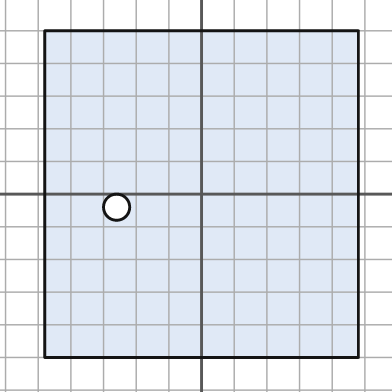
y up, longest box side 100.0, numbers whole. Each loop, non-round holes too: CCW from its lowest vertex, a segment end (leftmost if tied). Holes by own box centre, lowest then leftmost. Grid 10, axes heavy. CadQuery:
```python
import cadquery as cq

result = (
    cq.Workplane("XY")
    .moveTo(-48.0, -50.0)
    .lineTo(48.0, -50.0)
    .lineTo(48.0, 50.0)
    .lineTo(-48.0, 50.0)
    .close()
    .moveTo(-26.0, -4.0)
    .circle(4.0)
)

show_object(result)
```